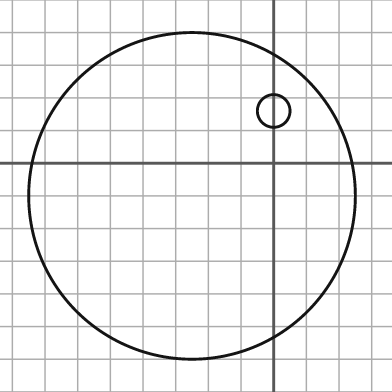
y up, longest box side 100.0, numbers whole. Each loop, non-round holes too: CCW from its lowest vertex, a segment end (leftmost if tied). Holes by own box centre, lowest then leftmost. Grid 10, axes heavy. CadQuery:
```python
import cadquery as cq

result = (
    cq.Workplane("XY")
    .moveTo(-25.0, -10.0)
    .circle(50.0)
    .moveTo(0.0, 16.0)
    .circle(5.0)
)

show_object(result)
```